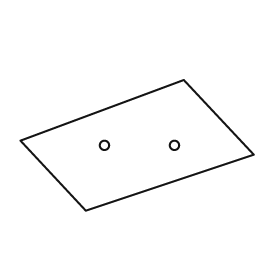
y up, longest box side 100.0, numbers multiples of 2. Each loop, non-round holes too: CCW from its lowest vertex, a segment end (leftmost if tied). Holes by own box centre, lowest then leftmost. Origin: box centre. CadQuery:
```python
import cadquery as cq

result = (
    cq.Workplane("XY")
    .moveTo(-22.0, -28.0)
    .lineTo(50.0, -4.0)
    .lineTo(20.0, 28.0)
    .lineTo(-50.0, 2.0)
    .close()
    .moveTo(-14.0, 0.0)
    .circle(2.0)
    .moveTo(16.0, 0.0)
    .circle(2.0)
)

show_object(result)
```